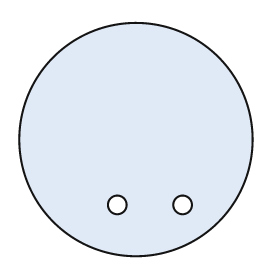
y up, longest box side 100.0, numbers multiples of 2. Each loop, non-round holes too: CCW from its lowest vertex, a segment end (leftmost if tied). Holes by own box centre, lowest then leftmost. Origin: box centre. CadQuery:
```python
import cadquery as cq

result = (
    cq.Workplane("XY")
    .moveTo(0.0, 0.0)
    .circle(50.0)
    .moveTo(-8.0, -28.0)
    .circle(4.0)
    .moveTo(20.0, -28.0)
    .circle(4.0)
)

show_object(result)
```